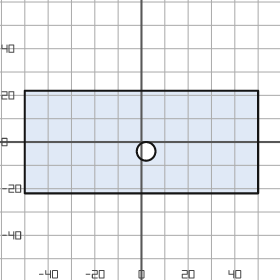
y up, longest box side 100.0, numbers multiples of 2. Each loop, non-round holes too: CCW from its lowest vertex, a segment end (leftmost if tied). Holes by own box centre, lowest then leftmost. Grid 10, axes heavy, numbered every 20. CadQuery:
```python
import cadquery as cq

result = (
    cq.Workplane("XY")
    .moveTo(-50.0, -22.0)
    .lineTo(50.0, -22.0)
    .lineTo(50.0, 22.0)
    .lineTo(-50.0, 22.0)
    .close()
    .moveTo(2.0, -4.0)
    .circle(4.0)
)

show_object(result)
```